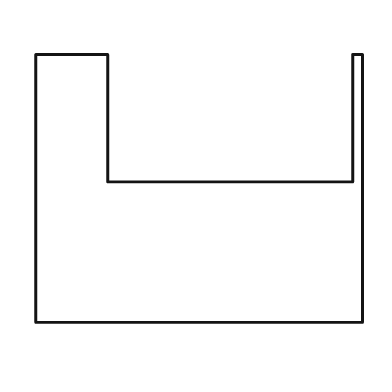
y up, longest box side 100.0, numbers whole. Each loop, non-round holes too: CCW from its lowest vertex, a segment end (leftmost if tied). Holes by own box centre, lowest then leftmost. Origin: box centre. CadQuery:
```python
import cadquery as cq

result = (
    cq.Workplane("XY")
    .moveTo(-50.0, -41.0)
    .lineTo(50.0, -41.0)
    .lineTo(50.0, 41.0)
    .lineTo(47.0, 41.0)
    .lineTo(47.0, 2.0)
    .lineTo(-28.0, 2.0)
    .lineTo(-28.0, 41.0)
    .lineTo(-50.0, 41.0)
    .close()
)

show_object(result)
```